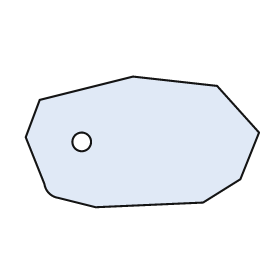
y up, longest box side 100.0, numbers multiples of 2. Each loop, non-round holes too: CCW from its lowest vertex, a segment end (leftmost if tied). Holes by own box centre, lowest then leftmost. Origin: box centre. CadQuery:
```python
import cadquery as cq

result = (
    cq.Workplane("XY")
    .moveTo(-20.0, -28.0)
    .lineTo(26.0, -26.0)
    .lineTo(42.0, -16.0)
    .lineTo(50.0, 4.0)
    .lineTo(32.0, 24.0)
    .lineTo(-4.0, 28.0)
    .lineTo(-44.0, 18.0)
    .lineTo(-50.0, 2.0)
    .lineTo(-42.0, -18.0)
    .threePointArc((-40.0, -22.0), (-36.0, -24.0))
    .close()
    .moveTo(-26.0, 0.0)
    .circle(4.0)
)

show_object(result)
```